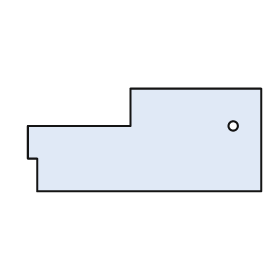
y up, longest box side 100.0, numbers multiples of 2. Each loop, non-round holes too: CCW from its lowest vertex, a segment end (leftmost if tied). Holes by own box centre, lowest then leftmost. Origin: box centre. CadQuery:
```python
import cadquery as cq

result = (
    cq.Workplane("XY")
    .moveTo(-46.0, -22.0)
    .lineTo(50.0, -22.0)
    .lineTo(50.0, 22.0)
    .lineTo(-6.0, 22.0)
    .lineTo(-6.0, 6.0)
    .lineTo(-50.0, 6.0)
    .lineTo(-50.0, -8.0)
    .lineTo(-46.0, -8.0)
    .close()
    .moveTo(38.0, 6.0)
    .circle(2.0)
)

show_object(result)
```